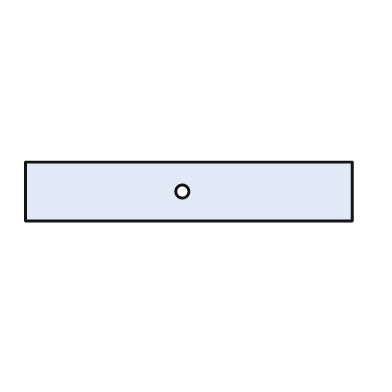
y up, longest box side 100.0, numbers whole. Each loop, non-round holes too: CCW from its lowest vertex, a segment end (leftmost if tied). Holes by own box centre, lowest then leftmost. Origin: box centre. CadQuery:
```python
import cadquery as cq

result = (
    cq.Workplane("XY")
    .moveTo(-50.0, -9.0)
    .lineTo(50.0, -9.0)
    .lineTo(50.0, 9.0)
    .lineTo(-50.0, 9.0)
    .close()
    .moveTo(-2.0, 0.0)
    .circle(2.0)
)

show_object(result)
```